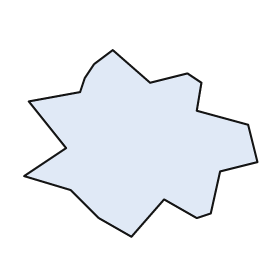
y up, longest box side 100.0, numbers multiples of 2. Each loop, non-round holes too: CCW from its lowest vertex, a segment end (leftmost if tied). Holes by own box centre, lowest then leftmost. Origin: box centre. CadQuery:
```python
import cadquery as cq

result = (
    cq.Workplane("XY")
    .moveTo(-4.0, -40.0)
    .lineTo(10.0, -24.0)
    .lineTo(24.0, -32.0)
    .lineTo(30.0, -30.0)
    .lineTo(34.0, -12.0)
    .lineTo(50.0, -8.0)
    .lineTo(46.0, 8.0)
    .lineTo(24.0, 14.0)
    .lineTo(26.0, 26.0)
    .lineTo(20.0, 30.0)
    .lineTo(4.0, 26.0)
    .lineTo(-12.0, 40.0)
    .lineTo(-20.0, 34.0)
    .lineTo(-24.0, 28.0)
    .lineTo(-26.0, 22.0)
    .lineTo(-48.0, 18.0)
    .lineTo(-32.0, -2.0)
    .lineTo(-50.0, -14.0)
    .lineTo(-30.0, -20.0)
    .lineTo(-18.0, -32.0)
    .close()
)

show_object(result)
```